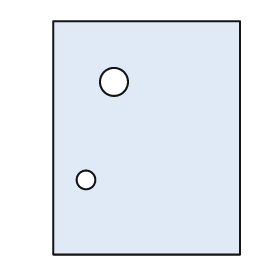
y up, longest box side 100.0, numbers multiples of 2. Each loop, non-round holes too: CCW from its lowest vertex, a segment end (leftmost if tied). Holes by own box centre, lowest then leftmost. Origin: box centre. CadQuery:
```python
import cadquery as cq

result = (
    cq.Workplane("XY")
    .moveTo(-40.0, -50.0)
    .lineTo(40.0, -50.0)
    .lineTo(40.0, 50.0)
    .lineTo(-40.0, 50.0)
    .close()
    .moveTo(-26.0, -18.0)
    .circle(4.0)
    .moveTo(-14.0, 24.0)
    .circle(6.0)
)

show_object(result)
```